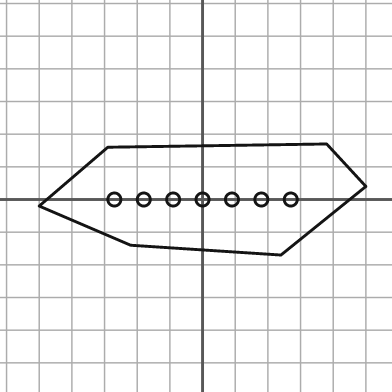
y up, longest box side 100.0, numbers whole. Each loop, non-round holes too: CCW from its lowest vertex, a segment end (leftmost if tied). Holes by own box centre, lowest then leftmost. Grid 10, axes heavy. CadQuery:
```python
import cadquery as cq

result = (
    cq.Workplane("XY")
    .moveTo(24.0, -17.0)
    .lineTo(50.0, 4.0)
    .lineTo(38.0, 17.0)
    .lineTo(-29.0, 16.0)
    .lineTo(-50.0, -2.0)
    .lineTo(-22.0, -14.0)
    .close()
    .moveTo(-27.0, 0.0)
    .circle(2.0)
    .moveTo(-18.0, 0.0)
    .circle(2.0)
    .moveTo(-9.0, 0.0)
    .circle(2.0)
    .moveTo(0.0, 0.0)
    .circle(2.0)
    .moveTo(9.0, 0.0)
    .circle(2.0)
    .moveTo(18.0, 0.0)
    .circle(2.0)
    .moveTo(27.0, 0.0)
    .circle(2.0)
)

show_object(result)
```